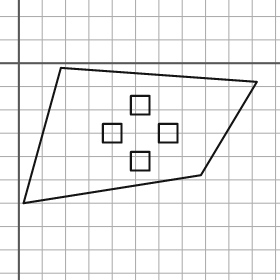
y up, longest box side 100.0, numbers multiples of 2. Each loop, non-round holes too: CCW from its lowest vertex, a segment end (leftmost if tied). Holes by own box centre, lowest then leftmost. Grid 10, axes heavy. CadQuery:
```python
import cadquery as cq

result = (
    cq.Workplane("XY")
    .moveTo(2.0, -60.0)
    .lineTo(78.0, -48.0)
    .lineTo(102.0, -8.0)
    .lineTo(18.0, -2.0)
    .close()
    .moveTo(48.0, -46.0)
    .lineTo(56.0, -46.0)
    .lineTo(56.0, -38.0)
    .lineTo(48.0, -38.0)
    .close()
    .moveTo(36.0, -34.0)
    .lineTo(44.0, -34.0)
    .lineTo(44.0, -26.0)
    .lineTo(36.0, -26.0)
    .close()
    .moveTo(60.0, -34.0)
    .lineTo(68.0, -34.0)
    .lineTo(68.0, -26.0)
    .lineTo(60.0, -26.0)
    .close()
    .moveTo(48.0, -22.0)
    .lineTo(56.0, -22.0)
    .lineTo(56.0, -14.0)
    .lineTo(48.0, -14.0)
    .close()
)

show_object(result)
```